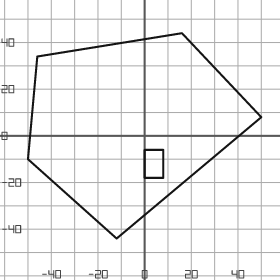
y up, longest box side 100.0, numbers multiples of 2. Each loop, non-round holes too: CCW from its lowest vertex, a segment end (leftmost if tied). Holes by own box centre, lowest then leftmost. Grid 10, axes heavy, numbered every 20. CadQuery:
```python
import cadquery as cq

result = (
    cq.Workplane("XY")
    .moveTo(-12.0, -44.0)
    .lineTo(50.0, 8.0)
    .lineTo(16.0, 44.0)
    .lineTo(-46.0, 34.0)
    .lineTo(-50.0, -10.0)
    .close()
    .moveTo(0.0, -18.0)
    .lineTo(8.0, -18.0)
    .lineTo(8.0, -6.0)
    .lineTo(0.0, -6.0)
    .close()
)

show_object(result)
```